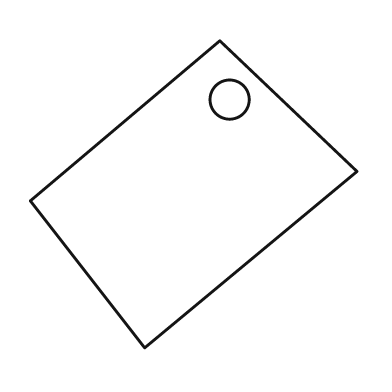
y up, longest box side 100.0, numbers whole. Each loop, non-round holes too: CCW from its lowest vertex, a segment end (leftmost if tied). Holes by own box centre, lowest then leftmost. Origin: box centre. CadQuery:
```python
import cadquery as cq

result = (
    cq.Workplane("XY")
    .moveTo(-15.0, -47.0)
    .lineTo(50.0, 7.0)
    .lineTo(8.0, 47.0)
    .lineTo(-50.0, -2.0)
    .close()
    .moveTo(11.0, 29.0)
    .circle(6.0)
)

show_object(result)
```